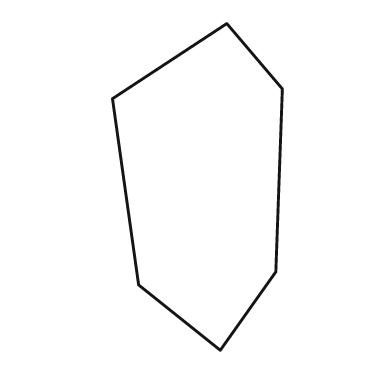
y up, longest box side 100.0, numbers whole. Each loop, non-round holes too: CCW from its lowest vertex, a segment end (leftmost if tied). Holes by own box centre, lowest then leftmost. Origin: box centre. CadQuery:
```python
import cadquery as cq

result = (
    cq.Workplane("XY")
    .moveTo(7.0, -50.0)
    .lineTo(24.0, -26.0)
    .lineTo(26.0, 30.0)
    .lineTo(9.0, 50.0)
    .lineTo(-26.0, 27.0)
    .lineTo(-18.0, -30.0)
    .close()
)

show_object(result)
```